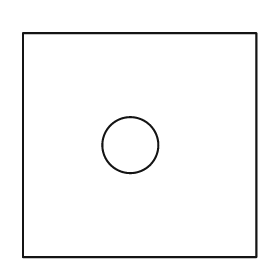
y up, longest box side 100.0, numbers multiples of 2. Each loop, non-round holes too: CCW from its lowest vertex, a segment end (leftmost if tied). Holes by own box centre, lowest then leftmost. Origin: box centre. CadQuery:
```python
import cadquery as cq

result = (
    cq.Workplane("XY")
    .moveTo(-50.0, -48.0)
    .lineTo(50.0, -48.0)
    .lineTo(50.0, 48.0)
    .lineTo(-50.0, 48.0)
    .close()
    .moveTo(-4.0, 0.0)
    .circle(12.0)
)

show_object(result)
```